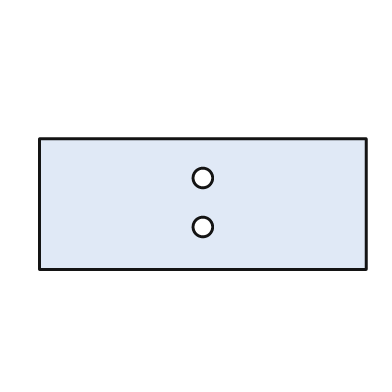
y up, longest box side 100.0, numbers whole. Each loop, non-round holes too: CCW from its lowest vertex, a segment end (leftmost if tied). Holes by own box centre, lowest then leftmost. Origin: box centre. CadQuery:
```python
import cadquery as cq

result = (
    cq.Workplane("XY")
    .moveTo(-50.0, -20.0)
    .lineTo(50.0, -20.0)
    .lineTo(50.0, 20.0)
    .lineTo(-50.0, 20.0)
    .close()
    .moveTo(0.0, -7.0)
    .circle(3.0)
    .moveTo(0.0, 8.0)
    .circle(3.0)
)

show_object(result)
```